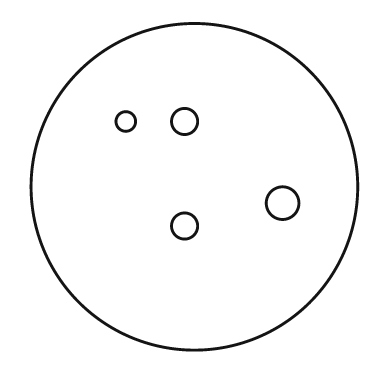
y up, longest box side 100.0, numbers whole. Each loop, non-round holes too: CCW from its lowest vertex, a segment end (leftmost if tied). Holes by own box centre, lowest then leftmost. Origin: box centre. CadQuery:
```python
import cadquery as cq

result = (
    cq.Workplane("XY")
    .moveTo(0.0, 0.0)
    .circle(50.0)
    .moveTo(-3.0, -12.0)
    .circle(4.0)
    .moveTo(27.0, -5.0)
    .circle(5.0)
    .moveTo(-21.0, 20.0)
    .circle(3.0)
    .moveTo(-3.0, 20.0)
    .circle(4.0)
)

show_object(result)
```